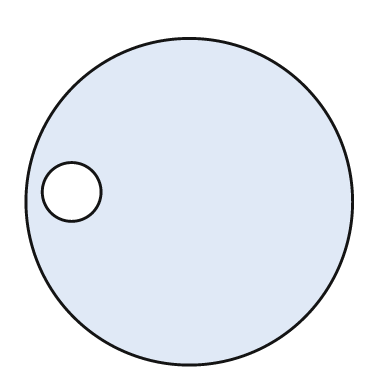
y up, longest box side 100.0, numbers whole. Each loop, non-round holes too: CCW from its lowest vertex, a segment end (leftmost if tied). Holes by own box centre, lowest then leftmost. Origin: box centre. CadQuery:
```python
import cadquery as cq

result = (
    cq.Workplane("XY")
    .moveTo(0.0, 0.0)
    .circle(50.0)
    .moveTo(-36.0, 3.0)
    .circle(9.0)
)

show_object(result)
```